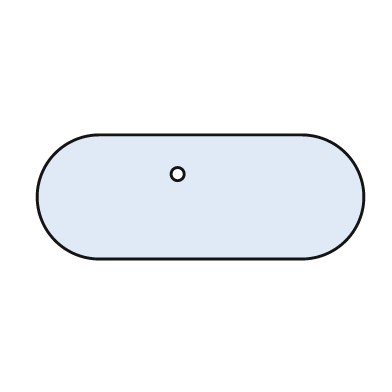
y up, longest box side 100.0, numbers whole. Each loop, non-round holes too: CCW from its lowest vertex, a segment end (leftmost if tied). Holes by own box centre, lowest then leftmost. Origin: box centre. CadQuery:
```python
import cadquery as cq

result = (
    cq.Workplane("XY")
    .moveTo(-31.0, -19.0)
    .lineTo(31.0, -19.0)
    .threePointArc((50.0, 0.0), (31.0, 19.0))
    .lineTo(-31.0, 19.0)
    .threePointArc((-50.0, 0.0), (-31.0, -19.0))
    .close()
    .moveTo(-7.0, 7.0)
    .circle(2.0)
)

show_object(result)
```